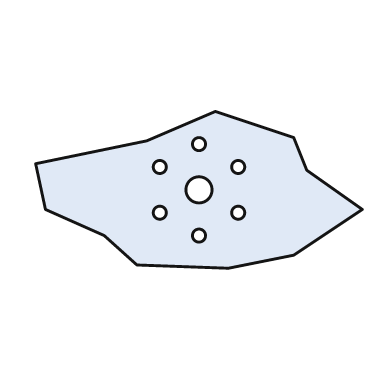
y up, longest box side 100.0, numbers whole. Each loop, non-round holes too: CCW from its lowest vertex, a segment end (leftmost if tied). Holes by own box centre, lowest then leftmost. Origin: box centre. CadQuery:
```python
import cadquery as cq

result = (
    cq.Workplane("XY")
    .moveTo(9.0, -24.0)
    .lineTo(29.0, -20.0)
    .lineTo(50.0, -6.0)
    .lineTo(33.0, 6.0)
    .lineTo(29.0, 16.0)
    .lineTo(5.0, 24.0)
    .lineTo(-16.0, 15.0)
    .lineTo(-50.0, 8.0)
    .lineTo(-47.0, -6.0)
    .lineTo(-29.0, -14.0)
    .lineTo(-19.0, -23.0)
    .close()
    .moveTo(0.0, -14.0)
    .circle(2.0)
    .moveTo(-12.0, -7.0)
    .circle(2.0)
    .moveTo(12.0, -7.0)
    .circle(2.0)
    .moveTo(0.0, 0.0)
    .circle(4.0)
    .moveTo(-12.0, 7.0)
    .circle(2.0)
    .moveTo(12.0, 7.0)
    .circle(2.0)
    .moveTo(0.0, 14.0)
    .circle(2.0)
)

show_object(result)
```